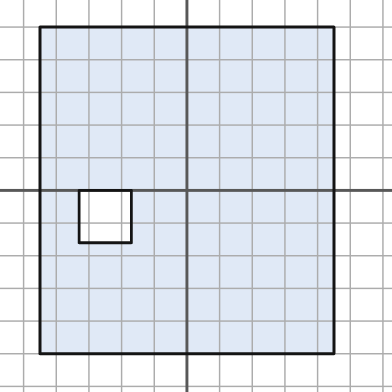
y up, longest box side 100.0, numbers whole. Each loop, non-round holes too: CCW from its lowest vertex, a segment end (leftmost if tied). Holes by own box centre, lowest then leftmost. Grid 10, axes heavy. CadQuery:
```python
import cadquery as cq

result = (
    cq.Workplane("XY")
    .moveTo(-45.0, -50.0)
    .lineTo(45.0, -50.0)
    .lineTo(45.0, 50.0)
    .lineTo(-45.0, 50.0)
    .close()
    .moveTo(-33.0, -16.0)
    .lineTo(-17.0, -16.0)
    .lineTo(-17.0, 0.0)
    .lineTo(-33.0, 0.0)
    .close()
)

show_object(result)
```